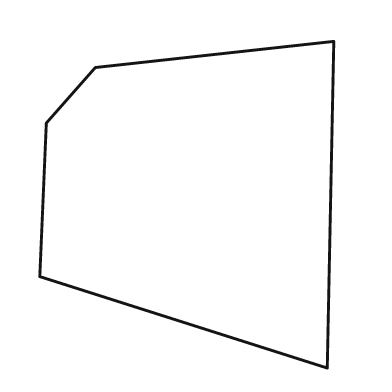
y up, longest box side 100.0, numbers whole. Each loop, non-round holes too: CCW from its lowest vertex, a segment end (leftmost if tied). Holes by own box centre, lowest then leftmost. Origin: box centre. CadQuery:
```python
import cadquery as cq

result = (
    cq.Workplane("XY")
    .moveTo(43.0, -50.0)
    .lineTo(45.0, 50.0)
    .lineTo(-28.0, 42.0)
    .lineTo(-43.0, 25.0)
    .lineTo(-45.0, -22.0)
    .close()
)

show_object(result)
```